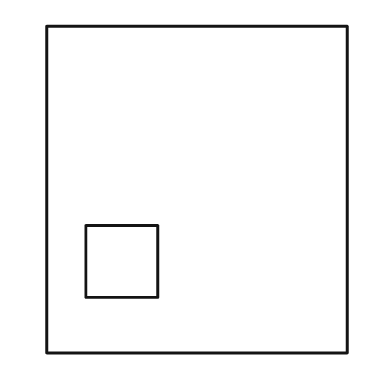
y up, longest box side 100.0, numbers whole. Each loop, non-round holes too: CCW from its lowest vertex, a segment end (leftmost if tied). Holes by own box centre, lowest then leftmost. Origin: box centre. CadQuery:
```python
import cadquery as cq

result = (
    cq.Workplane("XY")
    .moveTo(-46.0, -50.0)
    .lineTo(46.0, -50.0)
    .lineTo(46.0, 50.0)
    .lineTo(-46.0, 50.0)
    .close()
    .moveTo(-34.0, -33.0)
    .lineTo(-12.0, -33.0)
    .lineTo(-12.0, -11.0)
    .lineTo(-34.0, -11.0)
    .close()
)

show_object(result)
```